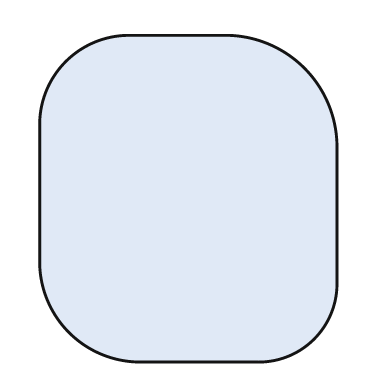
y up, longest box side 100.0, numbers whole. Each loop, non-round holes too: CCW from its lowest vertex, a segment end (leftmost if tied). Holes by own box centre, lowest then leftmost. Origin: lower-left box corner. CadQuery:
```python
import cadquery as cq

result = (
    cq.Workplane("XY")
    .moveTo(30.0, 0.0)
    .lineTo(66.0, 0.0)
    .threePointArc((84.0, 7.0), (91.0, 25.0))
    .lineTo(91.0, 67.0)
    .threePointArc((81.0, 90.0), (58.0, 100.0))
    .lineTo(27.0, 100.0)
    .threePointArc((8.0, 92.0), (0.0, 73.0))
    .lineTo(0.0, 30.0)
    .threePointArc((9.0, 9.0), (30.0, 0.0))
    .close()
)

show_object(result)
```